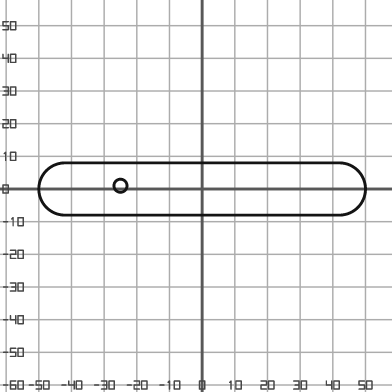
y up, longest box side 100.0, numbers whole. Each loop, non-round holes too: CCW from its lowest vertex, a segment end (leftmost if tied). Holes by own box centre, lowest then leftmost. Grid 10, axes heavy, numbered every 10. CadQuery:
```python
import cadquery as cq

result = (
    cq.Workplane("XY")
    .moveTo(-42.0, -8.0)
    .lineTo(42.0, -8.0)
    .threePointArc((50.0, 0.0), (42.0, 8.0))
    .lineTo(-42.0, 8.0)
    .threePointArc((-50.0, 0.0), (-42.0, -8.0))
    .close()
    .moveTo(-25.0, 1.0)
    .circle(2.0)
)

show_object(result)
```